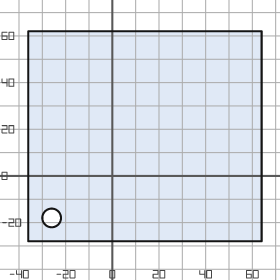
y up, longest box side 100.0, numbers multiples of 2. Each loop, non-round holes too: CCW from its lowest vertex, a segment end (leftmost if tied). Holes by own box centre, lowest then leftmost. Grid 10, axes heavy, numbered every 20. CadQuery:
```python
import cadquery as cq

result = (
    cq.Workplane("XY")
    .moveTo(-36.0, -28.0)
    .lineTo(64.0, -28.0)
    .lineTo(64.0, 62.0)
    .lineTo(-36.0, 62.0)
    .close()
    .moveTo(-26.0, -18.0)
    .circle(4.0)
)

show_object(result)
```